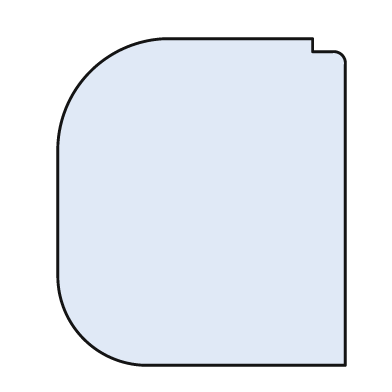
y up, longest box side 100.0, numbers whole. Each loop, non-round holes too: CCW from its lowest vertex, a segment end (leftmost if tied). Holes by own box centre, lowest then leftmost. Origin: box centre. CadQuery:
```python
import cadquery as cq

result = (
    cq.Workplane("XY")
    .moveTo(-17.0, -50.0)
    .lineTo(44.0, -50.0)
    .lineTo(44.0, 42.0)
    .threePointArc((43.0, 45.0), (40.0, 46.0))
    .lineTo(34.0, 46.0)
    .lineTo(34.0, 50.0)
    .lineTo(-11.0, 50.0)
    .threePointArc((-34.0, 40.0), (-44.0, 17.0))
    .lineTo(-44.0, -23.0)
    .threePointArc((-36.0, -42.0), (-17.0, -50.0))
    .close()
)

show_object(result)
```